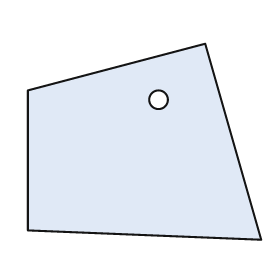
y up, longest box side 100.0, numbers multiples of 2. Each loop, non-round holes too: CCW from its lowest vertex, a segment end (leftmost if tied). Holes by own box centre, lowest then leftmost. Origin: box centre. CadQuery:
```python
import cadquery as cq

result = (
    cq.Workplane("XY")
    .moveTo(50.0, -42.0)
    .lineTo(26.0, 42.0)
    .lineTo(-50.0, 22.0)
    .lineTo(-50.0, -38.0)
    .close()
    .moveTo(6.0, 18.0)
    .circle(4.0)
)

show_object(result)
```